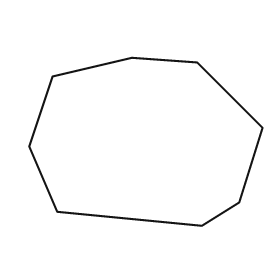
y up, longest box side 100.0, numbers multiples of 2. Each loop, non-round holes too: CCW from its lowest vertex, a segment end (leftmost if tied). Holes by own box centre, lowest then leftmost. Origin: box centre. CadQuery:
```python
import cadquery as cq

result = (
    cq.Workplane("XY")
    .moveTo(24.0, -36.0)
    .lineTo(40.0, -26.0)
    .lineTo(50.0, 6.0)
    .lineTo(22.0, 34.0)
    .lineTo(-6.0, 36.0)
    .lineTo(-40.0, 28.0)
    .lineTo(-50.0, -2.0)
    .lineTo(-38.0, -30.0)
    .close()
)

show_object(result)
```